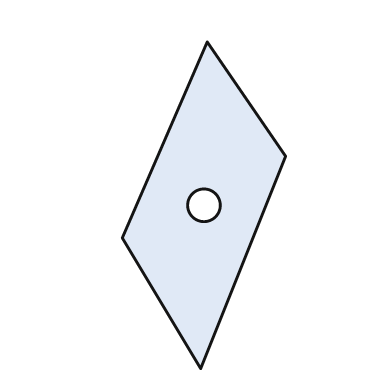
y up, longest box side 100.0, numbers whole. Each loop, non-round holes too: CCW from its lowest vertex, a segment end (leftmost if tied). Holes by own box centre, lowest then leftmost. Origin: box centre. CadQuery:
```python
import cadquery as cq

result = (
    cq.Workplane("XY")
    .moveTo(-1.0, -50.0)
    .lineTo(25.0, 15.0)
    .lineTo(1.0, 50.0)
    .lineTo(-25.0, -10.0)
    .close()
    .moveTo(0.0, 0.0)
    .circle(5.0)
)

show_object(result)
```